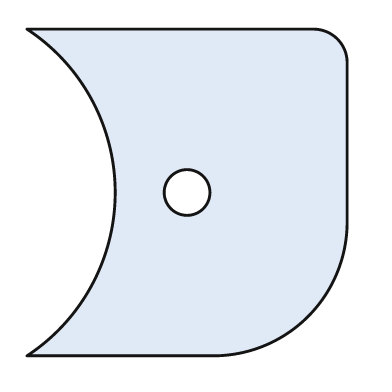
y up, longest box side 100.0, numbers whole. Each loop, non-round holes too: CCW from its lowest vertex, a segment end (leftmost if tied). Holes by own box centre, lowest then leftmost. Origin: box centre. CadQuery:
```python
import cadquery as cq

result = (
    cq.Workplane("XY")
    .moveTo(-49.0, -50.0)
    .lineTo(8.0, -50.0)
    .threePointArc((37.0, -38.0), (49.0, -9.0))
    .lineTo(49.0, 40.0)
    .threePointArc((46.0, 47.0), (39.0, 50.0))
    .lineTo(-49.0, 50.0)
    .threePointArc((-22.0, 0.0), (-49.0, -50.0))
    .close()
    .moveTo(0.0, 0.0)
    .circle(7.0)
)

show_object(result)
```